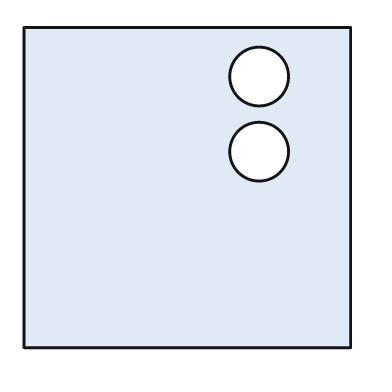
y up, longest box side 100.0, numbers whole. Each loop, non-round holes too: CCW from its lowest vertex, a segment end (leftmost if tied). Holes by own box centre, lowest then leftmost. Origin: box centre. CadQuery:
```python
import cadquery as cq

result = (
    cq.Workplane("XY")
    .moveTo(-50.0, -49.0)
    .lineTo(50.0, -49.0)
    .lineTo(50.0, 49.0)
    .lineTo(-50.0, 49.0)
    .close()
    .moveTo(22.0, 11.0)
    .circle(9.0)
    .moveTo(22.0, 34.0)
    .circle(9.0)
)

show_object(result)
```